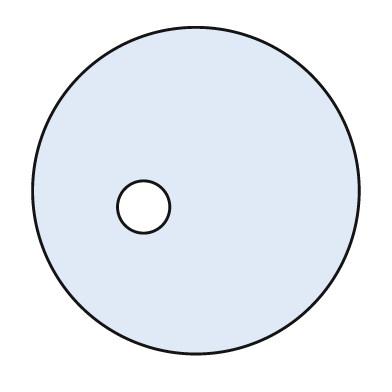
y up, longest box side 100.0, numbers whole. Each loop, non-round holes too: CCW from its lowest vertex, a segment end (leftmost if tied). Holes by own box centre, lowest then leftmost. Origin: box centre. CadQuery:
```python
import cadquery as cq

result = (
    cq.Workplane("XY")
    .moveTo(0.0, 0.0)
    .circle(50.0)
    .moveTo(-16.0, -5.0)
    .circle(8.0)
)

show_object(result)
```